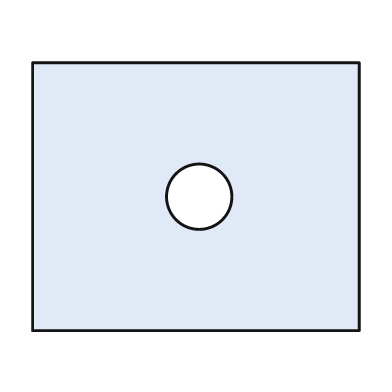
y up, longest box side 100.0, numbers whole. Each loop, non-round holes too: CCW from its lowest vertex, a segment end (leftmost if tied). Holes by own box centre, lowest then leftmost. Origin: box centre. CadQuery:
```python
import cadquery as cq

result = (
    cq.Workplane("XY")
    .moveTo(-50.0, -41.0)
    .lineTo(50.0, -41.0)
    .lineTo(50.0, 41.0)
    .lineTo(-50.0, 41.0)
    .close()
    .moveTo(1.0, 0.0)
    .circle(10.0)
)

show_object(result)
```